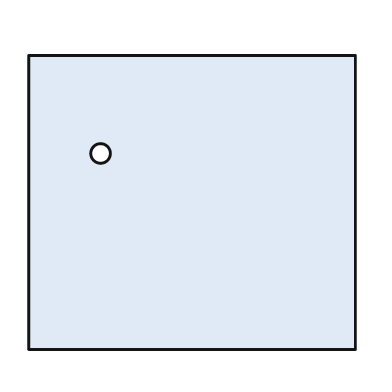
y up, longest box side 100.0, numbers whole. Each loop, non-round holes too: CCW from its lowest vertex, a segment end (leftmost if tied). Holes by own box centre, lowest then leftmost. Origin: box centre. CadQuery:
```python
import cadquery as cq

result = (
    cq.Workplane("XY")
    .moveTo(-50.0, -45.0)
    .lineTo(50.0, -45.0)
    .lineTo(50.0, 45.0)
    .lineTo(-50.0, 45.0)
    .close()
    .moveTo(-28.0, 15.0)
    .circle(3.0)
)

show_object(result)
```